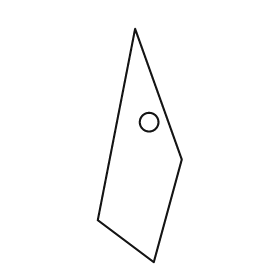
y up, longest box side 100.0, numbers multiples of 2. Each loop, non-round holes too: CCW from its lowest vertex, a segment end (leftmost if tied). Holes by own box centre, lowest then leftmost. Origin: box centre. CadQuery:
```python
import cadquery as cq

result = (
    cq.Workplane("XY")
    .moveTo(6.0, -50.0)
    .lineTo(18.0, -6.0)
    .lineTo(-2.0, 50.0)
    .lineTo(-18.0, -32.0)
    .close()
    .moveTo(4.0, 10.0)
    .circle(4.0)
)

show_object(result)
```